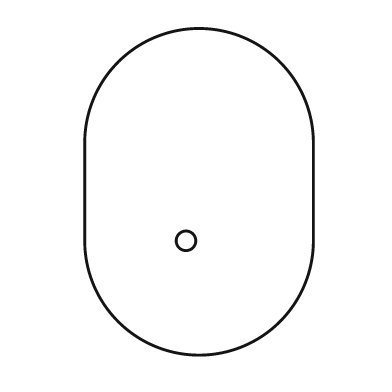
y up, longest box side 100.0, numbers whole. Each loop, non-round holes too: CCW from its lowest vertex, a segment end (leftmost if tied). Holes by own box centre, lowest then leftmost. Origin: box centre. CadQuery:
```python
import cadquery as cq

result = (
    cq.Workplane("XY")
    .moveTo(-35.0, -15.0)
    .threePointArc((0.0, -50.0), (35.0, -15.0))
    .lineTo(35.0, 15.0)
    .threePointArc((0.0, 50.0), (-35.0, 15.0))
    .close()
    .moveTo(-4.0, -15.0)
    .circle(3.0)
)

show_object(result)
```